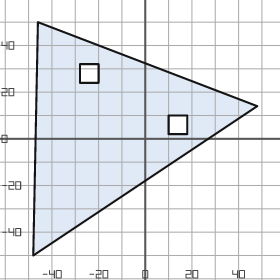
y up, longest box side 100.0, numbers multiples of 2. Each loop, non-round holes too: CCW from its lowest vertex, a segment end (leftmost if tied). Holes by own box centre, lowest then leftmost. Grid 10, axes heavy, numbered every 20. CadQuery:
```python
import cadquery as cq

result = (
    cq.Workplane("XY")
    .moveTo(-48.0, -50.0)
    .lineTo(48.0, 14.0)
    .lineTo(-46.0, 50.0)
    .close()
    .moveTo(10.0, 2.0)
    .lineTo(18.0, 2.0)
    .lineTo(18.0, 10.0)
    .lineTo(10.0, 10.0)
    .close()
    .moveTo(-28.0, 24.0)
    .lineTo(-20.0, 24.0)
    .lineTo(-20.0, 32.0)
    .lineTo(-28.0, 32.0)
    .close()
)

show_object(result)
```